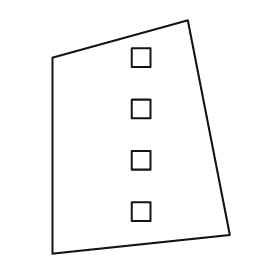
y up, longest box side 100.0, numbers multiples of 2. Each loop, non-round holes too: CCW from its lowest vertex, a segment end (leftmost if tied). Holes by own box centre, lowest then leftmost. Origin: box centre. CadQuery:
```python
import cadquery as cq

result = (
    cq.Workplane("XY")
    .moveTo(-38.0, -50.0)
    .lineTo(38.0, -42.0)
    .lineTo(20.0, 50.0)
    .lineTo(-38.0, 34.0)
    .close()
    .moveTo(-4.0, -36.0)
    .lineTo(4.0, -36.0)
    .lineTo(4.0, -28.0)
    .lineTo(-4.0, -28.0)
    .close()
    .moveTo(-4.0, -14.0)
    .lineTo(4.0, -14.0)
    .lineTo(4.0, -6.0)
    .lineTo(-4.0, -6.0)
    .close()
    .moveTo(-4.0, 8.0)
    .lineTo(4.0, 8.0)
    .lineTo(4.0, 16.0)
    .lineTo(-4.0, 16.0)
    .close()
    .moveTo(-4.0, 30.0)
    .lineTo(4.0, 30.0)
    .lineTo(4.0, 38.0)
    .lineTo(-4.0, 38.0)
    .close()
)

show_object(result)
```